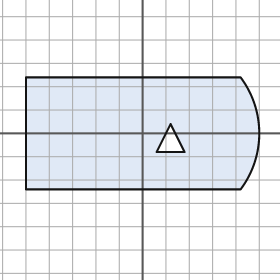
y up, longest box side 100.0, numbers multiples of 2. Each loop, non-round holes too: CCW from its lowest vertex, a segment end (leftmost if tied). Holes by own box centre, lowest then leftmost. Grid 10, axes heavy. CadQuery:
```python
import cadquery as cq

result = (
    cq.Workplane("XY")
    .moveTo(-50.0, -24.0)
    .lineTo(42.0, -24.0)
    .threePointArc((50.0, 0.0), (42.0, 24.0))
    .lineTo(-50.0, 24.0)
    .close()
    .moveTo(6.0, -8.0)
    .lineTo(18.0, -8.0)
    .lineTo(12.0, 4.0)
    .close()
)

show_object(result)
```